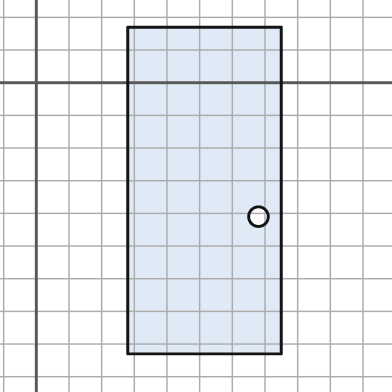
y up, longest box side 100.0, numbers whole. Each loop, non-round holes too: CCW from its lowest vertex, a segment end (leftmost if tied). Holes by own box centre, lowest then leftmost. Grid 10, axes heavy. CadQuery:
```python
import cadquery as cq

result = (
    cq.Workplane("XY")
    .moveTo(28.0, -83.0)
    .lineTo(75.0, -83.0)
    .lineTo(75.0, 17.0)
    .lineTo(28.0, 17.0)
    .close()
    .moveTo(68.0, -41.0)
    .circle(3.0)
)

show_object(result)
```